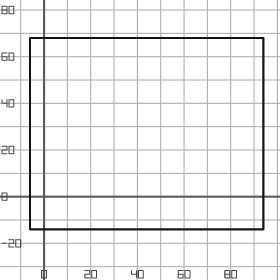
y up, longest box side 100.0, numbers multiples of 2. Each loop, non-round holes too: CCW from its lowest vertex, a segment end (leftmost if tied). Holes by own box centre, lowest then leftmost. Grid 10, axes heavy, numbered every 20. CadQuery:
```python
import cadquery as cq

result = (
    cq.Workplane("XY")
    .moveTo(-6.0, -14.0)
    .lineTo(94.0, -14.0)
    .lineTo(94.0, 68.0)
    .lineTo(-6.0, 68.0)
    .close()
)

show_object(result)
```